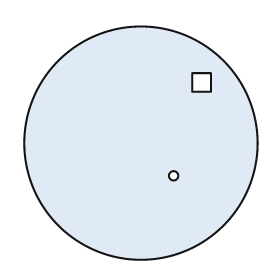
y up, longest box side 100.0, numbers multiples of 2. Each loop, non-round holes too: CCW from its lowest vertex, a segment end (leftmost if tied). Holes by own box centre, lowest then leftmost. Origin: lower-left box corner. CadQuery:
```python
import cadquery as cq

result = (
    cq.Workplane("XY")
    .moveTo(50.0, 50.0)
    .circle(50.0)
    .moveTo(64.0, 36.0)
    .circle(2.0)
    .moveTo(72.0, 72.0)
    .lineTo(80.0, 72.0)
    .lineTo(80.0, 80.0)
    .lineTo(72.0, 80.0)
    .close()
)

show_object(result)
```